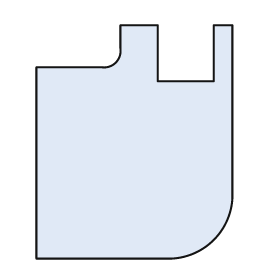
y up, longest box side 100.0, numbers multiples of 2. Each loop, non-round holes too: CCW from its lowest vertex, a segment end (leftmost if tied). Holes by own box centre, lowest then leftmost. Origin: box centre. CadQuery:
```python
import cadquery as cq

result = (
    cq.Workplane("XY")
    .moveTo(-42.0, -50.0)
    .lineTo(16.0, -50.0)
    .threePointArc((34.0, -42.0), (42.0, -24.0))
    .lineTo(42.0, 50.0)
    .lineTo(34.0, 50.0)
    .lineTo(34.0, 26.0)
    .lineTo(10.0, 26.0)
    .lineTo(10.0, 50.0)
    .lineTo(-6.0, 50.0)
    .lineTo(-6.0, 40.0)
    .threePointArc((-8.0, 34.0), (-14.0, 32.0))
    .lineTo(-42.0, 32.0)
    .close()
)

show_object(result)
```